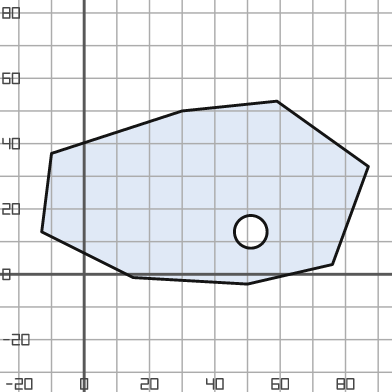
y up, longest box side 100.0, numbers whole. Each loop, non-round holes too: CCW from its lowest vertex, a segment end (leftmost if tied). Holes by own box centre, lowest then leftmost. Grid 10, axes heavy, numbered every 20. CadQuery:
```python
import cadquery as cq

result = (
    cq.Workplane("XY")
    .moveTo(50.0, -3.0)
    .lineTo(76.0, 3.0)
    .lineTo(87.0, 33.0)
    .lineTo(59.0, 53.0)
    .lineTo(30.0, 50.0)
    .lineTo(-10.0, 37.0)
    .lineTo(-13.0, 13.0)
    .lineTo(15.0, -1.0)
    .close()
    .moveTo(51.0, 13.0)
    .circle(5.0)
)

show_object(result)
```